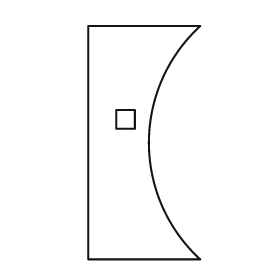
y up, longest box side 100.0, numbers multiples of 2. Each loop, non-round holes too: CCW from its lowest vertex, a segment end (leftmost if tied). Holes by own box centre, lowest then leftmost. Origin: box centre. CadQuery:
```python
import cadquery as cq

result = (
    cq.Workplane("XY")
    .moveTo(-24.0, -50.0)
    .lineTo(24.0, -50.0)
    .threePointArc((2.0, 0.0), (24.0, 50.0))
    .lineTo(-24.0, 50.0)
    .close()
    .moveTo(-12.0, 6.0)
    .lineTo(-4.0, 6.0)
    .lineTo(-4.0, 14.0)
    .lineTo(-12.0, 14.0)
    .close()
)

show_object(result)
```